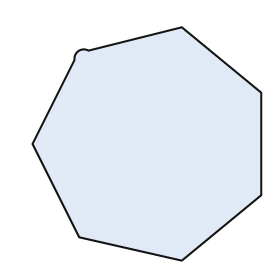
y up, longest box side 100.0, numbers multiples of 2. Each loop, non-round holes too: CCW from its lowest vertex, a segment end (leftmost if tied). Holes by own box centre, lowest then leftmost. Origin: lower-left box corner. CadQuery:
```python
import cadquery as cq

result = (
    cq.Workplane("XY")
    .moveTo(64.0, 0.0)
    .lineTo(98.0, 28.0)
    .lineTo(98.0, 72.0)
    .lineTo(64.0, 100.0)
    .lineTo(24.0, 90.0)
    .threePointArc((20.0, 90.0), (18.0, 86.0))
    .lineTo(0.0, 50.0)
    .lineTo(20.0, 10.0)
    .close()
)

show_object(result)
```